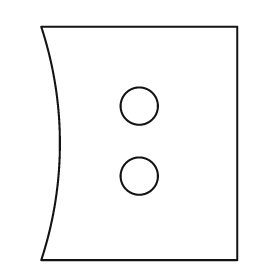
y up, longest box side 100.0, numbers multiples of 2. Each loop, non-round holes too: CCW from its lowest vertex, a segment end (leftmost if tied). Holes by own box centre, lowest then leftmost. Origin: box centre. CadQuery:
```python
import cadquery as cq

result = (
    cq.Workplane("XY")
    .moveTo(-42.0, -50.0)
    .lineTo(42.0, -50.0)
    .lineTo(42.0, 50.0)
    .lineTo(-42.0, 50.0)
    .threePointArc((-34.0, 0.0), (-42.0, -50.0))
    .close()
    .moveTo(0.0, -14.0)
    .circle(8.0)
    .moveTo(0.0, 16.0)
    .circle(8.0)
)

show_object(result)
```